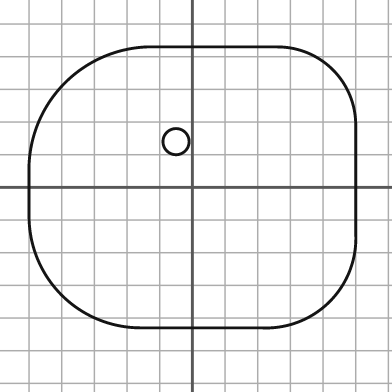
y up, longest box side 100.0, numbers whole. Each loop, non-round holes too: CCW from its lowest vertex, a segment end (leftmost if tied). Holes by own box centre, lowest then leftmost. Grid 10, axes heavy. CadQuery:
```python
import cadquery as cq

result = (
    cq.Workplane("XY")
    .moveTo(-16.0, -43.0)
    .lineTo(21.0, -43.0)
    .threePointArc((42.0, -35.0), (50.0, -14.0))
    .lineTo(50.0, 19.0)
    .threePointArc((43.0, 36.0), (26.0, 43.0))
    .lineTo(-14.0, 43.0)
    .threePointArc((-39.0, 32.0), (-50.0, 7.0))
    .lineTo(-50.0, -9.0)
    .threePointArc((-40.0, -33.0), (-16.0, -43.0))
    .close()
    .moveTo(-5.0, 14.0)
    .circle(4.0)
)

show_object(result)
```